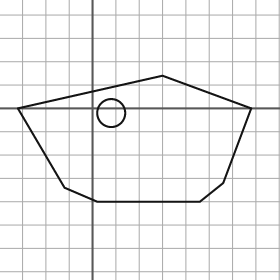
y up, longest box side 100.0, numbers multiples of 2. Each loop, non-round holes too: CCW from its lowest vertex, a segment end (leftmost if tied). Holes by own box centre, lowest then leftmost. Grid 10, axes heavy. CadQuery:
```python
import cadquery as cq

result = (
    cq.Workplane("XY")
    .moveTo(2.0, -40.0)
    .lineTo(46.0, -40.0)
    .lineTo(56.0, -32.0)
    .lineTo(68.0, 0.0)
    .lineTo(30.0, 14.0)
    .lineTo(-32.0, 0.0)
    .lineTo(-12.0, -34.0)
    .close()
    .moveTo(8.0, -2.0)
    .circle(6.0)
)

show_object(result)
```